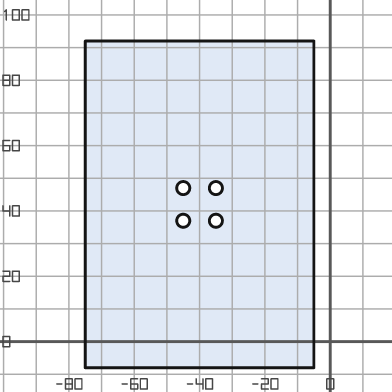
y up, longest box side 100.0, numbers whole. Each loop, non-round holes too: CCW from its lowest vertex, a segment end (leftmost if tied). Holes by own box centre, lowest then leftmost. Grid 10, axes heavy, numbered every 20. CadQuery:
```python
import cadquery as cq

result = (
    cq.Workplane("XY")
    .moveTo(-75.0, -8.0)
    .lineTo(-5.0, -8.0)
    .lineTo(-5.0, 92.0)
    .lineTo(-75.0, 92.0)
    .close()
    .moveTo(-45.0, 37.0)
    .circle(2.0)
    .moveTo(-35.0, 37.0)
    .circle(2.0)
    .moveTo(-45.0, 47.0)
    .circle(2.0)
    .moveTo(-35.0, 47.0)
    .circle(2.0)
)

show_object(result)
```